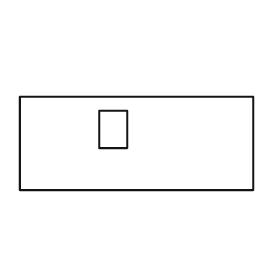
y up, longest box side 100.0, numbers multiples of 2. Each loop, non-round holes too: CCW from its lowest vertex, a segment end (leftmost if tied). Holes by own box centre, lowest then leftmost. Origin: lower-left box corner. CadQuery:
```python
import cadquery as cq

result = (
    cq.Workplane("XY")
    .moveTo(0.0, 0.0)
    .lineTo(100.0, 0.0)
    .lineTo(100.0, 40.0)
    .lineTo(0.0, 40.0)
    .close()
    .moveTo(34.0, 18.0)
    .lineTo(46.0, 18.0)
    .lineTo(46.0, 34.0)
    .lineTo(34.0, 34.0)
    .close()
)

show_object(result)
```